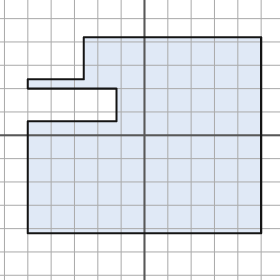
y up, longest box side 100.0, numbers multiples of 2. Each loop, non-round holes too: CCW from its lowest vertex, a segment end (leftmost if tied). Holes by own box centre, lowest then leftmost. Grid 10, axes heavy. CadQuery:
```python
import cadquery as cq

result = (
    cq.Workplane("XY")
    .moveTo(-50.0, -42.0)
    .lineTo(50.0, -42.0)
    .lineTo(50.0, 42.0)
    .lineTo(-26.0, 42.0)
    .lineTo(-26.0, 24.0)
    .lineTo(-50.0, 24.0)
    .lineTo(-50.0, 20.0)
    .lineTo(-12.0, 20.0)
    .lineTo(-12.0, 6.0)
    .lineTo(-50.0, 6.0)
    .close()
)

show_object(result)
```